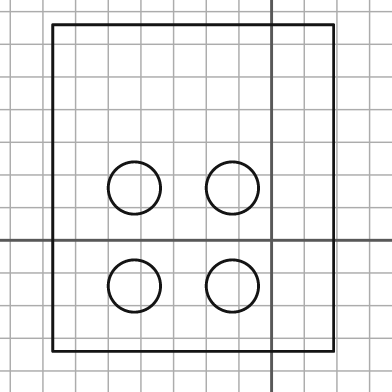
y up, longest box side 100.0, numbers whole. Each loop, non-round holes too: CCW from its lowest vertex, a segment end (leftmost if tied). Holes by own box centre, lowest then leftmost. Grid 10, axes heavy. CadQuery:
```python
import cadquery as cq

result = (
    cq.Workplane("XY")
    .moveTo(-67.0, -34.0)
    .lineTo(19.0, -34.0)
    .lineTo(19.0, 66.0)
    .lineTo(-67.0, 66.0)
    .close()
    .moveTo(-42.0, -14.0)
    .circle(8.0)
    .moveTo(-12.0, -14.0)
    .circle(8.0)
    .moveTo(-42.0, 16.0)
    .circle(8.0)
    .moveTo(-12.0, 16.0)
    .circle(8.0)
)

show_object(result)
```